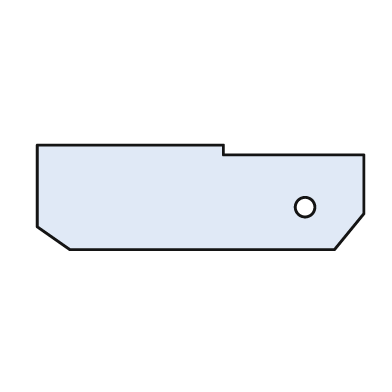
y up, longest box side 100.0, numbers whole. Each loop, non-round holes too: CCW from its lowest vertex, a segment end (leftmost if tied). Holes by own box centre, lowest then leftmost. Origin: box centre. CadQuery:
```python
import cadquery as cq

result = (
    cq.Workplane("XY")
    .moveTo(-40.0, -16.0)
    .lineTo(41.0, -16.0)
    .lineTo(50.0, -5.0)
    .lineTo(50.0, 13.0)
    .lineTo(7.0, 13.0)
    .lineTo(7.0, 16.0)
    .lineTo(-50.0, 16.0)
    .lineTo(-50.0, -9.0)
    .close()
    .moveTo(32.0, -3.0)
    .circle(3.0)
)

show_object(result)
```